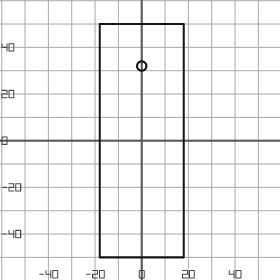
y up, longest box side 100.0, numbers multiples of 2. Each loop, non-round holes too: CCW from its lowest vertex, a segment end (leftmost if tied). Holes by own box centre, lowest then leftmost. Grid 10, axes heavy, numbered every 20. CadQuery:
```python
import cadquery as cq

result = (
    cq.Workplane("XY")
    .moveTo(-18.0, -50.0)
    .lineTo(18.0, -50.0)
    .lineTo(18.0, 50.0)
    .lineTo(-18.0, 50.0)
    .close()
    .moveTo(0.0, 32.0)
    .circle(2.0)
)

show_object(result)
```